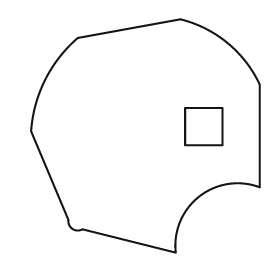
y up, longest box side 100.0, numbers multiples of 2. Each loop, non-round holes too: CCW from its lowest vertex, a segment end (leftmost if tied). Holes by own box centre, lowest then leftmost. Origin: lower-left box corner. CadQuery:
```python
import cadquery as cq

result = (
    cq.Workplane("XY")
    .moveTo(62.0, 0.0)
    .threePointArc((72.0, 24.0), (98.0, 28.0))
    .lineTo(98.0, 72.0)
    .threePointArc((84.0, 90.0), (64.0, 100.0))
    .lineTo(20.0, 92.0)
    .threePointArc((6.0, 74.0), (0.0, 52.0))
    .lineTo(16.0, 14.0)
    .threePointArc((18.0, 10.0), (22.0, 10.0))
    .close()
    .moveTo(66.0, 46.0)
    .lineTo(82.0, 46.0)
    .lineTo(82.0, 62.0)
    .lineTo(66.0, 62.0)
    .close()
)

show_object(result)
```